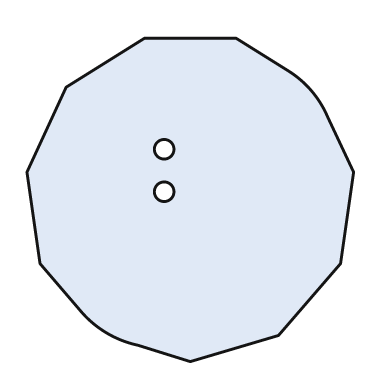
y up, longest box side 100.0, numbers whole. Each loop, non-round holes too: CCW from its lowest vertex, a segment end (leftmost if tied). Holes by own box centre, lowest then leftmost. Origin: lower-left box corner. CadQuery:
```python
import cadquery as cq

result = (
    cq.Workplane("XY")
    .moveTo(50.0, 0.0)
    .lineTo(77.0, 8.0)
    .lineTo(96.0, 30.0)
    .lineTo(100.0, 58.0)
    .lineTo(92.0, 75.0)
    .threePointArc((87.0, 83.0), (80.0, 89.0))
    .lineTo(64.0, 99.0)
    .lineTo(36.0, 99.0)
    .lineTo(12.0, 84.0)
    .lineTo(0.0, 58.0)
    .lineTo(4.0, 30.0)
    .lineTo(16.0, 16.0)
    .threePointArc((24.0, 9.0), (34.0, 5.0))
    .close()
    .moveTo(42.0, 52.0)
    .circle(3.0)
    .moveTo(42.0, 65.0)
    .circle(3.0)
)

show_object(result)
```